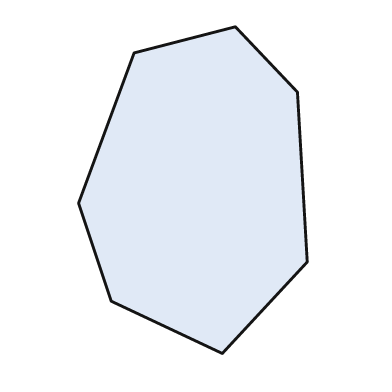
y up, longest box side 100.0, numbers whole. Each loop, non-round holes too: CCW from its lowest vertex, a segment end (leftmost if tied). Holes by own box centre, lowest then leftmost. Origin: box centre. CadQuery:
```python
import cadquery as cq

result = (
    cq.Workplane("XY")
    .moveTo(9.0, -50.0)
    .lineTo(35.0, -22.0)
    .lineTo(32.0, 30.0)
    .lineTo(13.0, 50.0)
    .lineTo(-18.0, 42.0)
    .lineTo(-35.0, -4.0)
    .lineTo(-25.0, -34.0)
    .close()
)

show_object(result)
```